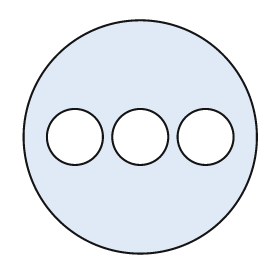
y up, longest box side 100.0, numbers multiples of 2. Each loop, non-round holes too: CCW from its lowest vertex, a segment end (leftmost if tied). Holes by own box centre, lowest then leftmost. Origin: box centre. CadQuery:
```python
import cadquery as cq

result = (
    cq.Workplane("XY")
    .moveTo(0.0, 0.0)
    .circle(50.0)
    .moveTo(-28.0, 0.0)
    .circle(12.0)
    .moveTo(0.0, 0.0)
    .circle(12.0)
    .moveTo(28.0, 0.0)
    .circle(12.0)
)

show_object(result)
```